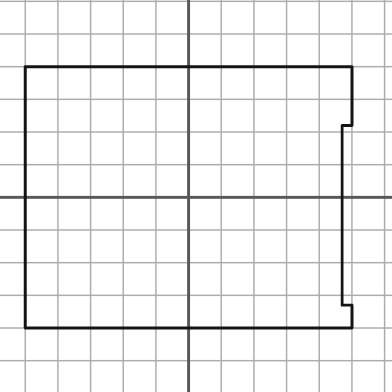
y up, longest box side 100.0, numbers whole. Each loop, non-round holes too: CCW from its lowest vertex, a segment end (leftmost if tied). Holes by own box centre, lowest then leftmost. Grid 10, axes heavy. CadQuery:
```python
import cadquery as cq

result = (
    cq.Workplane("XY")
    .moveTo(-50.0, -40.0)
    .lineTo(50.0, -40.0)
    .lineTo(50.0, -33.0)
    .lineTo(47.0, -33.0)
    .lineTo(47.0, 22.0)
    .lineTo(50.0, 22.0)
    .lineTo(50.0, 40.0)
    .lineTo(-50.0, 40.0)
    .close()
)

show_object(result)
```